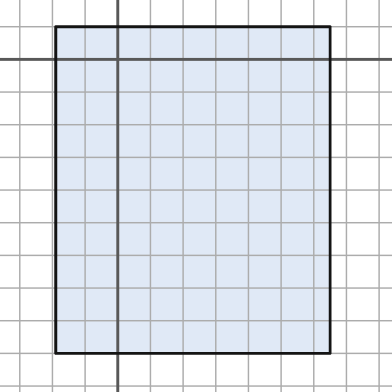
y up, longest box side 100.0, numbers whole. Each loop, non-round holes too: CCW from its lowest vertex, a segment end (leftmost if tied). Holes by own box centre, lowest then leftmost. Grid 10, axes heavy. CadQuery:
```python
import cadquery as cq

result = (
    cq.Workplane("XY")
    .moveTo(-19.0, -90.0)
    .lineTo(65.0, -90.0)
    .lineTo(65.0, 10.0)
    .lineTo(-19.0, 10.0)
    .close()
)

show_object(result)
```